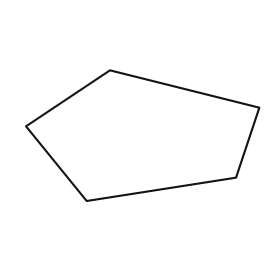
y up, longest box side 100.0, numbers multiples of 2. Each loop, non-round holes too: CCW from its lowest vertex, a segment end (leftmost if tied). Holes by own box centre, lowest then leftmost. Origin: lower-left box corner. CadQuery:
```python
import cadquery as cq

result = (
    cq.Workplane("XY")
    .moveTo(26.0, 0.0)
    .lineTo(90.0, 10.0)
    .lineTo(100.0, 40.0)
    .lineTo(36.0, 56.0)
    .lineTo(0.0, 32.0)
    .close()
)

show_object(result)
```